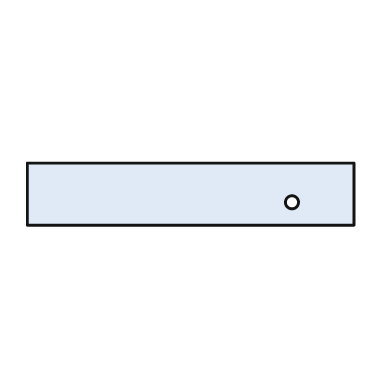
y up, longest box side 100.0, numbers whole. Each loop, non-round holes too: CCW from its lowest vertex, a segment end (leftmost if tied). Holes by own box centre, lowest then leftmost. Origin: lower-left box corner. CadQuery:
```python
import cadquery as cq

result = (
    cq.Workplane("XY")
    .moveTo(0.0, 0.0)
    .lineTo(100.0, 0.0)
    .lineTo(100.0, 19.0)
    .lineTo(0.0, 19.0)
    .close()
    .moveTo(81.0, 7.0)
    .circle(2.0)
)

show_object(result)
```